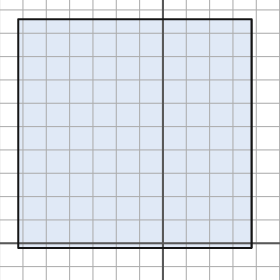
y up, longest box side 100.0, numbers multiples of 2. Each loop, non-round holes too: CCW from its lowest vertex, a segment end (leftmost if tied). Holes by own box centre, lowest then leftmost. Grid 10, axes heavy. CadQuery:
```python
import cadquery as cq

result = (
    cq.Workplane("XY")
    .moveTo(-62.0, -2.0)
    .lineTo(38.0, -2.0)
    .lineTo(38.0, 96.0)
    .lineTo(-62.0, 96.0)
    .close()
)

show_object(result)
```